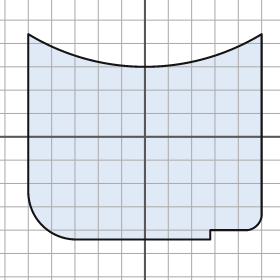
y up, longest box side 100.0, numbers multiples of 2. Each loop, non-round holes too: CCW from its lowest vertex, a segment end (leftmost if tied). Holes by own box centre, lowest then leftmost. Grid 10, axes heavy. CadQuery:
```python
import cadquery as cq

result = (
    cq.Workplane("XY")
    .moveTo(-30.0, -44.0)
    .lineTo(28.0, -44.0)
    .lineTo(28.0, -40.0)
    .lineTo(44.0, -40.0)
    .threePointArc((48.0, -38.0), (50.0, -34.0))
    .lineTo(50.0, 44.0)
    .threePointArc((0.0, 30.0), (-50.0, 44.0))
    .lineTo(-50.0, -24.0)
    .threePointArc((-44.0, -38.0), (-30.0, -44.0))
    .close()
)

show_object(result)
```